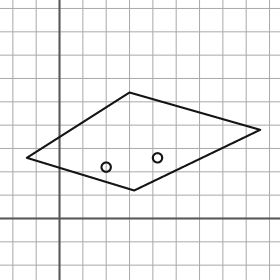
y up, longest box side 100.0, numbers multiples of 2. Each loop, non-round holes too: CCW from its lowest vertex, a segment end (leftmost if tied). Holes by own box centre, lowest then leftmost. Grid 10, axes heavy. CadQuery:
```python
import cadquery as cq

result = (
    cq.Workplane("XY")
    .moveTo(32.0, 12.0)
    .lineTo(86.0, 38.0)
    .lineTo(30.0, 54.0)
    .lineTo(-14.0, 26.0)
    .close()
    .moveTo(20.0, 22.0)
    .circle(2.0)
    .moveTo(42.0, 26.0)
    .circle(2.0)
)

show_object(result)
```